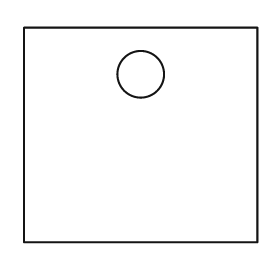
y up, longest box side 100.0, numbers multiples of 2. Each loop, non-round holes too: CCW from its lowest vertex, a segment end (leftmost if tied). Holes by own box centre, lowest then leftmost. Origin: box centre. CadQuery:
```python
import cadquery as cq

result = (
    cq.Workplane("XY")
    .moveTo(-50.0, -46.0)
    .lineTo(50.0, -46.0)
    .lineTo(50.0, 46.0)
    .lineTo(-50.0, 46.0)
    .close()
    .moveTo(0.0, 26.0)
    .circle(10.0)
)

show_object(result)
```